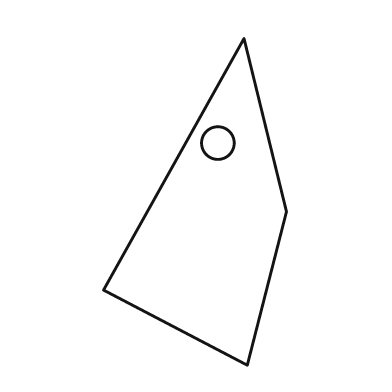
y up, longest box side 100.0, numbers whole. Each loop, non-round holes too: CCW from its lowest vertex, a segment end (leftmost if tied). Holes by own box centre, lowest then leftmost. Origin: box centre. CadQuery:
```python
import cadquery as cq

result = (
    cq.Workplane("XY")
    .moveTo(16.0, -50.0)
    .lineTo(28.0, -3.0)
    .lineTo(15.0, 50.0)
    .lineTo(-28.0, -27.0)
    .close()
    .moveTo(7.0, 18.0)
    .circle(5.0)
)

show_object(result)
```